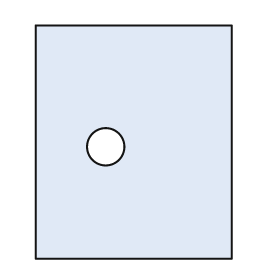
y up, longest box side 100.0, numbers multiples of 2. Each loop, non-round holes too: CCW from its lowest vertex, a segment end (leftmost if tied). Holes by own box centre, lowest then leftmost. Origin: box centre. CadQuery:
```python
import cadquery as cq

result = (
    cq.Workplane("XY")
    .moveTo(-42.0, -50.0)
    .lineTo(42.0, -50.0)
    .lineTo(42.0, 50.0)
    .lineTo(-42.0, 50.0)
    .close()
    .moveTo(-12.0, -2.0)
    .circle(8.0)
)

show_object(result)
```